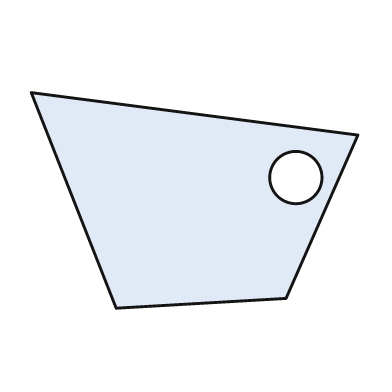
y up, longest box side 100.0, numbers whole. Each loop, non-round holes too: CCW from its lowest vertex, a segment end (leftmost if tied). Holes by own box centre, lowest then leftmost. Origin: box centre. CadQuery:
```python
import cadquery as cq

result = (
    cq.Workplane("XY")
    .moveTo(-24.0, -33.0)
    .lineTo(28.0, -30.0)
    .lineTo(50.0, 20.0)
    .lineTo(-50.0, 33.0)
    .close()
    .moveTo(31.0, 7.0)
    .circle(8.0)
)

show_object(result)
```